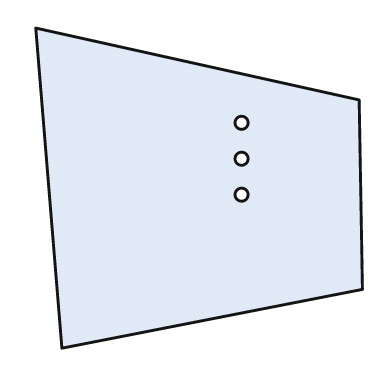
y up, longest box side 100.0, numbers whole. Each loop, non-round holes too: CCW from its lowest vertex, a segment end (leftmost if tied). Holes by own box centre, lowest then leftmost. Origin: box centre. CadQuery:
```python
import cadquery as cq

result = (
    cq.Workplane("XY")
    .moveTo(-42.0, -49.0)
    .lineTo(50.0, -31.0)
    .lineTo(49.0, 27.0)
    .lineTo(-50.0, 49.0)
    .close()
    .moveTo(13.0, -2.0)
    .circle(2.0)
    .moveTo(13.0, 9.0)
    .circle(2.0)
    .moveTo(13.0, 20.0)
    .circle(2.0)
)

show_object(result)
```